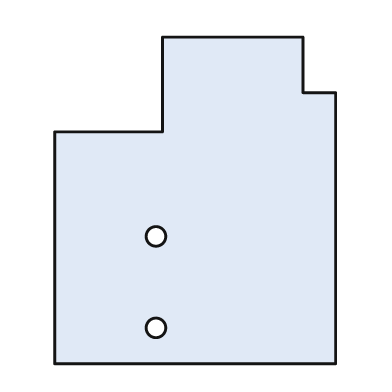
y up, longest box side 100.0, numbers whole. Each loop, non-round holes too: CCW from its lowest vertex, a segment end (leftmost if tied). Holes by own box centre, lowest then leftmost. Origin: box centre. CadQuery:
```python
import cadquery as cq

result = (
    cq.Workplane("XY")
    .moveTo(-43.0, -50.0)
    .lineTo(43.0, -50.0)
    .lineTo(43.0, 33.0)
    .lineTo(33.0, 33.0)
    .lineTo(33.0, 50.0)
    .lineTo(-10.0, 50.0)
    .lineTo(-10.0, 21.0)
    .lineTo(-43.0, 21.0)
    .close()
    .moveTo(-12.0, -39.0)
    .circle(3.0)
    .moveTo(-12.0, -11.0)
    .circle(3.0)
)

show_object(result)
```